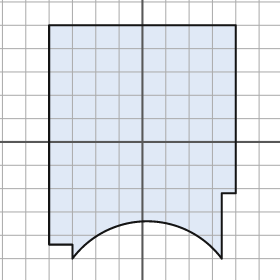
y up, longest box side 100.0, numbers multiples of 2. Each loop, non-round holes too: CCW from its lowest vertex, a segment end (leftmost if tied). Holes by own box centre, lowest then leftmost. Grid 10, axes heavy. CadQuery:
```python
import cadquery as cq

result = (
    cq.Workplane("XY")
    .moveTo(-30.0, -50.0)
    .threePointArc((2.0, -34.0), (34.0, -50.0))
    .lineTo(34.0, -22.0)
    .lineTo(40.0, -22.0)
    .lineTo(40.0, 50.0)
    .lineTo(-40.0, 50.0)
    .lineTo(-40.0, -44.0)
    .lineTo(-30.0, -44.0)
    .close()
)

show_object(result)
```